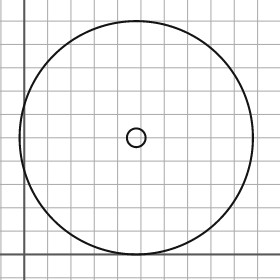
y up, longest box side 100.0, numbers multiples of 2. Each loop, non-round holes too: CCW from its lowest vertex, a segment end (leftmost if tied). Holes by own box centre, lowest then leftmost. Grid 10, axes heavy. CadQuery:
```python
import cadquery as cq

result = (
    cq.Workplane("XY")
    .moveTo(48.0, 50.0)
    .circle(50.0)
    .moveTo(48.0, 50.0)
    .circle(4.0)
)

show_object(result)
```